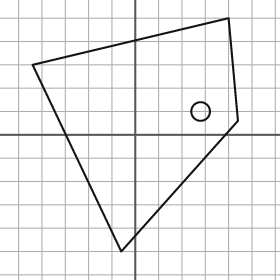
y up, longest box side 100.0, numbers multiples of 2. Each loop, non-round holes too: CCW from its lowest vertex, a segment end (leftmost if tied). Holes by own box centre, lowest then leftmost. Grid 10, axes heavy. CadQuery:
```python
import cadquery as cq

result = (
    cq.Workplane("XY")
    .moveTo(-6.0, -50.0)
    .lineTo(44.0, 6.0)
    .lineTo(40.0, 50.0)
    .lineTo(-44.0, 30.0)
    .close()
    .moveTo(28.0, 10.0)
    .circle(4.0)
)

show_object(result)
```